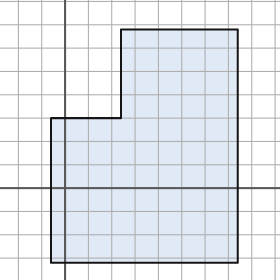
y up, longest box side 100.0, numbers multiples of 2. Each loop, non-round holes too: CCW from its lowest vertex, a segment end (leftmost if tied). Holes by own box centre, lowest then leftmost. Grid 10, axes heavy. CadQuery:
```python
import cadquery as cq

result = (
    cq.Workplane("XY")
    .moveTo(-6.0, -32.0)
    .lineTo(74.0, -32.0)
    .lineTo(74.0, 68.0)
    .lineTo(24.0, 68.0)
    .lineTo(24.0, 30.0)
    .lineTo(-6.0, 30.0)
    .close()
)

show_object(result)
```